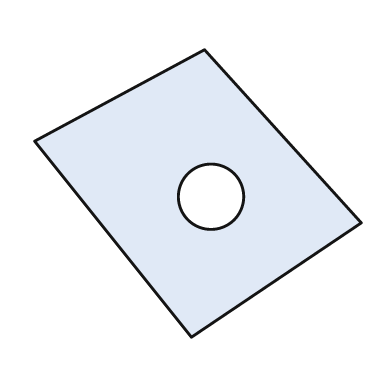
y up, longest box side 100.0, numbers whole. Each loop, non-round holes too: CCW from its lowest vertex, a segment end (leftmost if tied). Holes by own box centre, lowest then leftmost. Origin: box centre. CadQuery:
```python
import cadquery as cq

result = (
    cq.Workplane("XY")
    .moveTo(-2.0, -44.0)
    .lineTo(50.0, -9.0)
    .lineTo(2.0, 44.0)
    .lineTo(-50.0, 16.0)
    .close()
    .moveTo(4.0, -1.0)
    .circle(10.0)
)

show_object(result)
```